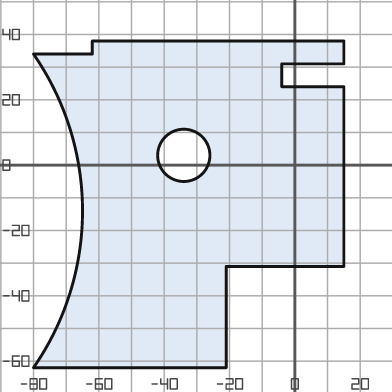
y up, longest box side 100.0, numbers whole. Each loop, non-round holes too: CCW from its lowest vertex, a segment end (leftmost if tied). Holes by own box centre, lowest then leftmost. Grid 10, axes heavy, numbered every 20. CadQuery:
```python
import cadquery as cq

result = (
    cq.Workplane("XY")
    .moveTo(-80.0, -62.0)
    .lineTo(-21.0, -62.0)
    .lineTo(-21.0, -31.0)
    .lineTo(15.0, -31.0)
    .lineTo(15.0, 24.0)
    .lineTo(-4.0, 24.0)
    .lineTo(-4.0, 31.0)
    .lineTo(15.0, 31.0)
    .lineTo(15.0, 38.0)
    .lineTo(-62.0, 38.0)
    .lineTo(-62.0, 34.0)
    .lineTo(-80.0, 34.0)
    .threePointArc((-65.0, -14.0), (-80.0, -62.0))
    .close()
    .moveTo(-34.0, 3.0)
    .circle(8.0)
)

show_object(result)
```